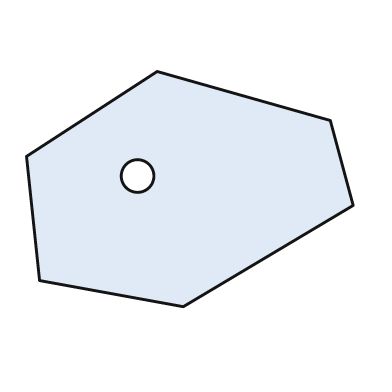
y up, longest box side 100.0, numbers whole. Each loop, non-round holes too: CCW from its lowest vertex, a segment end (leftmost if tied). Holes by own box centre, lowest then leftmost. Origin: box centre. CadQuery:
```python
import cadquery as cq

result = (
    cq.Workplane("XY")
    .moveTo(-2.0, -36.0)
    .lineTo(50.0, -5.0)
    .lineTo(43.0, 21.0)
    .lineTo(-10.0, 36.0)
    .lineTo(-50.0, 10.0)
    .lineTo(-46.0, -28.0)
    .close()
    .moveTo(-16.0, 4.0)
    .circle(5.0)
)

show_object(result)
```